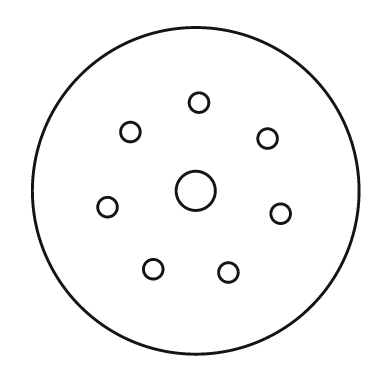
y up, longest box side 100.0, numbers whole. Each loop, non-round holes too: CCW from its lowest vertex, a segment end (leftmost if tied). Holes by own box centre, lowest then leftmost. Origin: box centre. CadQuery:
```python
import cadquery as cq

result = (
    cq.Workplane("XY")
    .moveTo(0.0, 0.0)
    .circle(50.0)
    .moveTo(10.0, -25.0)
    .circle(3.0)
    .moveTo(-13.0, -24.0)
    .circle(3.0)
    .moveTo(26.0, -7.0)
    .circle(3.0)
    .moveTo(-27.0, -5.0)
    .circle(3.0)
    .moveTo(0.0, 0.0)
    .circle(6.0)
    .moveTo(22.0, 16.0)
    .circle(3.0)
    .moveTo(-20.0, 18.0)
    .circle(3.0)
    .moveTo(1.0, 27.0)
    .circle(3.0)
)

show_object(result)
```